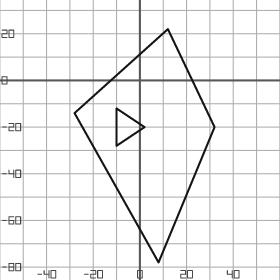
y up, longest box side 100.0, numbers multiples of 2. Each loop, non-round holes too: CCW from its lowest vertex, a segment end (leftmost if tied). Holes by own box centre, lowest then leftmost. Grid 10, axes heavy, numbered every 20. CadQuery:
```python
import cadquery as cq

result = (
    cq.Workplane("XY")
    .moveTo(8.0, -78.0)
    .lineTo(32.0, -20.0)
    .lineTo(12.0, 22.0)
    .lineTo(-28.0, -14.0)
    .close()
    .moveTo(-10.0, -28.0)
    .lineTo(2.0, -20.0)
    .lineTo(-10.0, -12.0)
    .close()
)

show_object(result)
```